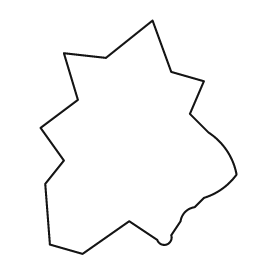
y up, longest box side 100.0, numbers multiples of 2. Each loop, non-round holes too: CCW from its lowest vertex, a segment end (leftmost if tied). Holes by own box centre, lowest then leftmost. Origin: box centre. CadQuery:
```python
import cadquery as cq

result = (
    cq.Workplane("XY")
    .moveTo(-24.0, -50.0)
    .lineTo(-4.0, -36.0)
    .lineTo(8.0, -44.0)
    .threePointArc((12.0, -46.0), (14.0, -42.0))
    .lineTo(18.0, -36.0)
    .threePointArc((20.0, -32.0), (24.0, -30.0))
    .lineTo(28.0, -26.0)
    .threePointArc((36.0, -22.0), (42.0, -16.0))
    .threePointArc((38.0, -6.0), (30.0, 2.0))
    .lineTo(22.0, 10.0)
    .lineTo(28.0, 24.0)
    .lineTo(14.0, 28.0)
    .lineTo(6.0, 50.0)
    .lineTo(-14.0, 34.0)
    .lineTo(-32.0, 36.0)
    .lineTo(-26.0, 16.0)
    .lineTo(-42.0, 4.0)
    .lineTo(-32.0, -10.0)
    .lineTo(-40.0, -20.0)
    .lineTo(-38.0, -46.0)
    .close()
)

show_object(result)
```